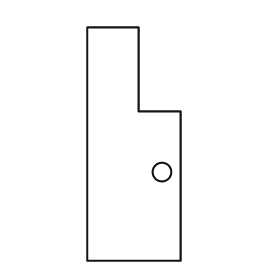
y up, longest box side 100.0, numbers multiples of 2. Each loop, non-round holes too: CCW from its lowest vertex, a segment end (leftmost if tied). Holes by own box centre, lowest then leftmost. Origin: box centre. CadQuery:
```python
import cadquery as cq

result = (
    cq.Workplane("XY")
    .moveTo(-20.0, -50.0)
    .lineTo(20.0, -50.0)
    .lineTo(20.0, 14.0)
    .lineTo(2.0, 14.0)
    .lineTo(2.0, 50.0)
    .lineTo(-20.0, 50.0)
    .close()
    .moveTo(12.0, -12.0)
    .circle(4.0)
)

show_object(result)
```